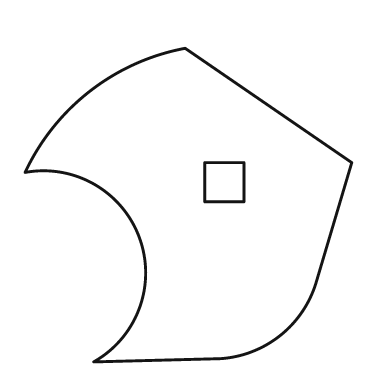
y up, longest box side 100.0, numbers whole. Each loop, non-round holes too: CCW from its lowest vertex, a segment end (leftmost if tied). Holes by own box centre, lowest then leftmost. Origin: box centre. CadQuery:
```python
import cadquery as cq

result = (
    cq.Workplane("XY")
    .moveTo(-29.0, -48.0)
    .lineTo(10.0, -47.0)
    .threePointArc((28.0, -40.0), (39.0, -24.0))
    .lineTo(50.0, 13.0)
    .lineTo(-1.0, 48.0)
    .threePointArc((-30.0, 35.0), (-50.0, 10.0))
    .threePointArc((-15.0, -10.0), (-29.0, -48.0))
    .close()
    .moveTo(5.0, 1.0)
    .lineTo(17.0, 1.0)
    .lineTo(17.0, 13.0)
    .lineTo(5.0, 13.0)
    .close()
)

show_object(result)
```